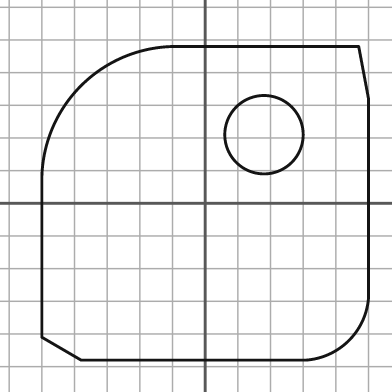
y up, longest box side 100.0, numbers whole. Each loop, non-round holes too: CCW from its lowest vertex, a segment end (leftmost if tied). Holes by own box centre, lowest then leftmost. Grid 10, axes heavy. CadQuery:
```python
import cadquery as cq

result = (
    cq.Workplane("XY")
    .moveTo(-38.0, -48.0)
    .lineTo(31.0, -48.0)
    .threePointArc((44.0, -42.0), (50.0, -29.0))
    .lineTo(50.0, 32.0)
    .lineTo(47.0, 48.0)
    .lineTo(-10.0, 48.0)
    .threePointArc((-38.0, 36.0), (-50.0, 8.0))
    .lineTo(-50.0, -41.0)
    .close()
    .moveTo(18.0, 21.0)
    .circle(12.0)
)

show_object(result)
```